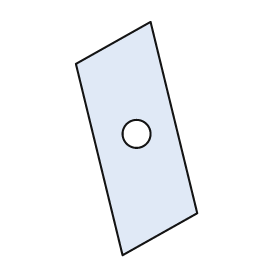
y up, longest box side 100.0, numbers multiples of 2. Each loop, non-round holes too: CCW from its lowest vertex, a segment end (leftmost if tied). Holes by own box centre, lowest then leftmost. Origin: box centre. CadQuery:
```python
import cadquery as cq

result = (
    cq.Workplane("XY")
    .moveTo(-6.0, -50.0)
    .lineTo(26.0, -32.0)
    .lineTo(6.0, 50.0)
    .lineTo(-26.0, 32.0)
    .close()
    .moveTo(0.0, 2.0)
    .circle(6.0)
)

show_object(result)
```